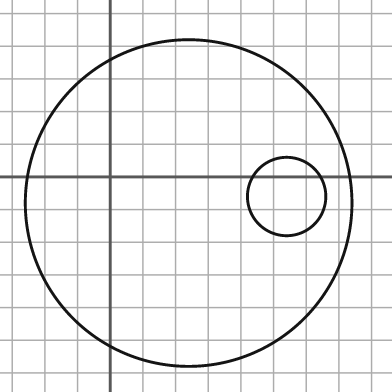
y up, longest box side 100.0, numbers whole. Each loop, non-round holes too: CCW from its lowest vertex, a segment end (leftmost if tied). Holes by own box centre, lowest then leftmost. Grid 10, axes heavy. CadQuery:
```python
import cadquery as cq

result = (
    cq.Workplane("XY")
    .moveTo(24.0, -8.0)
    .circle(50.0)
    .moveTo(54.0, -6.0)
    .circle(12.0)
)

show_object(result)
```